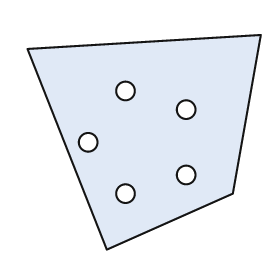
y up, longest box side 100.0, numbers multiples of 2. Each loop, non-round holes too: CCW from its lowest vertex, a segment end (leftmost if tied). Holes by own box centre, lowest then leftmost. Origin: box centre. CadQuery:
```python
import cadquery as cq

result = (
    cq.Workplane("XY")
    .moveTo(-16.0, -46.0)
    .lineTo(38.0, -22.0)
    .lineTo(50.0, 46.0)
    .lineTo(-50.0, 40.0)
    .close()
    .moveTo(-8.0, -22.0)
    .circle(4.0)
    .moveTo(18.0, -14.0)
    .circle(4.0)
    .moveTo(-24.0, 0.0)
    .circle(4.0)
    .moveTo(18.0, 14.0)
    .circle(4.0)
    .moveTo(-8.0, 22.0)
    .circle(4.0)
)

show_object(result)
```